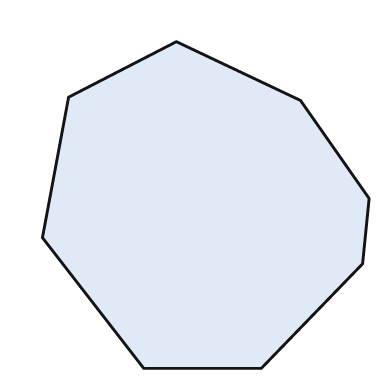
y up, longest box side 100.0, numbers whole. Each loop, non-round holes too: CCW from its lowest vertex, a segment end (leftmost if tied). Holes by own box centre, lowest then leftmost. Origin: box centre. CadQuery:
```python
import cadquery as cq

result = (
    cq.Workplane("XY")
    .moveTo(-19.0, -50.0)
    .lineTo(17.0, -50.0)
    .lineTo(48.0, -18.0)
    .lineTo(50.0, 2.0)
    .lineTo(29.0, 32.0)
    .lineTo(-9.0, 50.0)
    .lineTo(-42.0, 33.0)
    .lineTo(-50.0, -10.0)
    .close()
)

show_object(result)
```